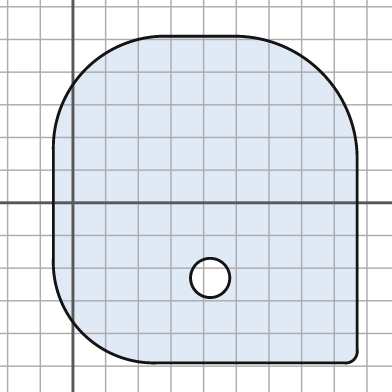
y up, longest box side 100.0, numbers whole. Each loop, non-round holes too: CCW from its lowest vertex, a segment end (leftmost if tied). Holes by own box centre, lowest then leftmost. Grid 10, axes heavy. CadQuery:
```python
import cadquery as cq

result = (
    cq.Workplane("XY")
    .moveTo(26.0, -49.0)
    .lineTo(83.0, -49.0)
    .threePointArc((86.0, -48.0), (87.0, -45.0))
    .lineTo(87.0, 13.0)
    .threePointArc((76.0, 40.0), (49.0, 51.0))
    .lineTo(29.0, 51.0)
    .threePointArc((4.0, 41.0), (-6.0, 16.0))
    .lineTo(-6.0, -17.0)
    .threePointArc((3.0, -40.0), (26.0, -49.0))
    .close()
    .moveTo(42.0, -23.0)
    .circle(6.0)
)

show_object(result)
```